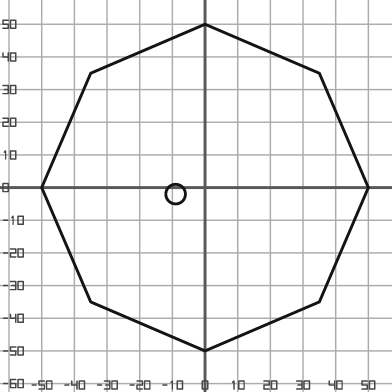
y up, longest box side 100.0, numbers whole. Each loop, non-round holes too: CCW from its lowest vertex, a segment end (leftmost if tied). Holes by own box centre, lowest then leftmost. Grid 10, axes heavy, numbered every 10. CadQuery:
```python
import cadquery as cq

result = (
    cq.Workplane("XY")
    .moveTo(0.0, -50.0)
    .lineTo(35.0, -35.0)
    .lineTo(50.0, 0.0)
    .lineTo(35.0, 35.0)
    .lineTo(0.0, 50.0)
    .lineTo(-35.0, 35.0)
    .lineTo(-50.0, 0.0)
    .lineTo(-35.0, -35.0)
    .close()
    .moveTo(-9.0, -2.0)
    .circle(3.0)
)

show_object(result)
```